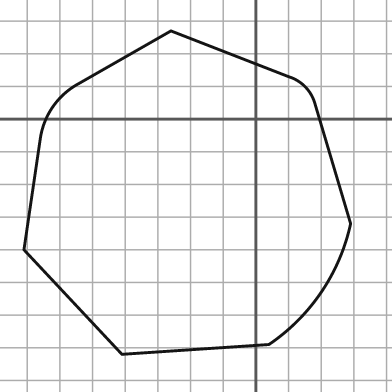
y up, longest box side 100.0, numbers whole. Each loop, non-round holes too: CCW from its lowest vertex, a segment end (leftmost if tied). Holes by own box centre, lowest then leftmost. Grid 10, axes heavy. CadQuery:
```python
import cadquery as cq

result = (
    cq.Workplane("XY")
    .moveTo(-41.0, -72.0)
    .lineTo(4.0, -69.0)
    .threePointArc((20.0, -53.0), (29.0, -32.0))
    .lineTo(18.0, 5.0)
    .threePointArc((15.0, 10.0), (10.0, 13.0))
    .lineTo(-26.0, 27.0)
    .lineTo(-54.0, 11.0)
    .threePointArc((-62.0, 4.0), (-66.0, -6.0))
    .lineTo(-71.0, -40.0)
    .close()
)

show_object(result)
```